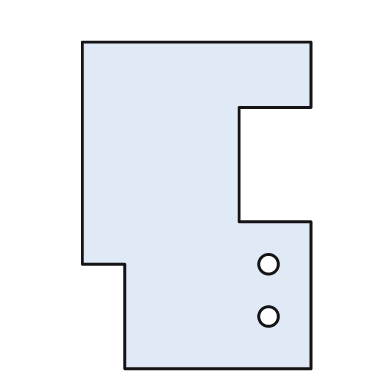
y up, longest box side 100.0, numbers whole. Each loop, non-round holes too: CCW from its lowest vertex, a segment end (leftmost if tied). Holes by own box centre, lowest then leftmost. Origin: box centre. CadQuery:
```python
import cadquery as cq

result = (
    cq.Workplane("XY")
    .moveTo(-22.0, -50.0)
    .lineTo(35.0, -50.0)
    .lineTo(35.0, -5.0)
    .lineTo(13.0, -5.0)
    .lineTo(13.0, 30.0)
    .lineTo(35.0, 30.0)
    .lineTo(35.0, 50.0)
    .lineTo(-35.0, 50.0)
    .lineTo(-35.0, -18.0)
    .lineTo(-22.0, -18.0)
    .close()
    .moveTo(22.0, -34.0)
    .circle(3.0)
    .moveTo(22.0, -18.0)
    .circle(3.0)
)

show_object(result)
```